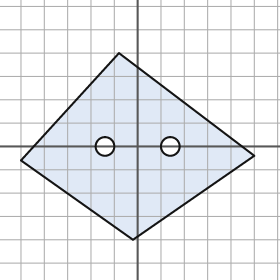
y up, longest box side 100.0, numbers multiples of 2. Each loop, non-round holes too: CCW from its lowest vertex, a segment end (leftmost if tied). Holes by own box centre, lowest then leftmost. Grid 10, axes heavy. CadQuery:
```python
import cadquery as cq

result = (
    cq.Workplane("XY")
    .moveTo(-2.0, -40.0)
    .lineTo(50.0, -4.0)
    .lineTo(-8.0, 40.0)
    .lineTo(-50.0, -6.0)
    .close()
    .moveTo(-14.0, 0.0)
    .circle(4.0)
    .moveTo(14.0, 0.0)
    .circle(4.0)
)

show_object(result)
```